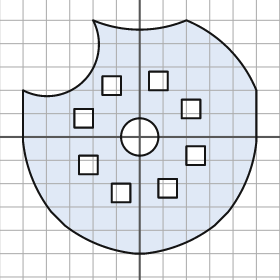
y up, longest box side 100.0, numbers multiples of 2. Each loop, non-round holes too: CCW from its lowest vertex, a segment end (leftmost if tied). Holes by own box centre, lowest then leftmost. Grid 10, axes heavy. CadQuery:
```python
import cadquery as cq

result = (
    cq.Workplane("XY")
    .moveTo(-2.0, -50.0)
    .lineTo(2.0, -50.0)
    .threePointArc((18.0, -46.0), (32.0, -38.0))
    .lineTo(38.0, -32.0)
    .threePointArc((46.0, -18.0), (50.0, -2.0))
    .lineTo(50.0, 20.0)
    .threePointArc((38.0, 38.0), (20.0, 50.0))
    .threePointArc((0.0, 46.0), (-20.0, 50.0))
    .threePointArc((-24.0, 24.0), (-50.0, 20.0))
    .lineTo(-50.0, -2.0)
    .threePointArc((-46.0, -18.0), (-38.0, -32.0))
    .lineTo(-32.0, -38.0)
    .threePointArc((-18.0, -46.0), (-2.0, -50.0))
    .close()
    .moveTo(-12.0, -28.0)
    .lineTo(-4.0, -28.0)
    .lineTo(-4.0, -20.0)
    .lineTo(-12.0, -20.0)
    .close()
    .moveTo(8.0, -26.0)
    .lineTo(16.0, -26.0)
    .lineTo(16.0, -18.0)
    .lineTo(8.0, -18.0)
    .close()
    .moveTo(-26.0, -16.0)
    .lineTo(-18.0, -16.0)
    .lineTo(-18.0, -8.0)
    .lineTo(-26.0, -8.0)
    .close()
    .moveTo(20.0, -12.0)
    .lineTo(28.0, -12.0)
    .lineTo(28.0, -4.0)
    .lineTo(20.0, -4.0)
    .close()
    .moveTo(0.0, 0.0)
    .circle(8.0)
    .moveTo(-28.0, 4.0)
    .lineTo(-20.0, 4.0)
    .lineTo(-20.0, 12.0)
    .lineTo(-28.0, 12.0)
    .close()
    .moveTo(18.0, 8.0)
    .lineTo(26.0, 8.0)
    .lineTo(26.0, 16.0)
    .lineTo(18.0, 16.0)
    .close()
    .moveTo(-16.0, 18.0)
    .lineTo(-8.0, 18.0)
    .lineTo(-8.0, 26.0)
    .lineTo(-16.0, 26.0)
    .close()
    .moveTo(4.0, 20.0)
    .lineTo(12.0, 20.0)
    .lineTo(12.0, 28.0)
    .lineTo(4.0, 28.0)
    .close()
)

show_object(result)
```